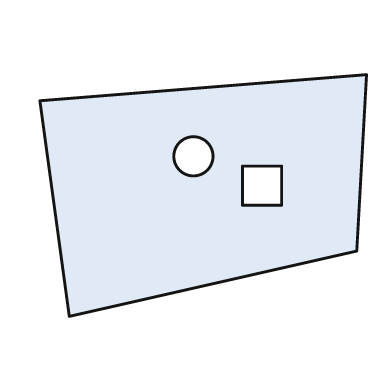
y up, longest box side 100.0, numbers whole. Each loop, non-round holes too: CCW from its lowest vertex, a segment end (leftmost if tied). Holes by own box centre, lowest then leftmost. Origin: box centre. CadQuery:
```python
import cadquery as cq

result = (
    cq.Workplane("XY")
    .moveTo(-41.0, -37.0)
    .lineTo(47.0, -17.0)
    .lineTo(50.0, 37.0)
    .lineTo(-50.0, 29.0)
    .close()
    .moveTo(12.0, -3.0)
    .lineTo(24.0, -3.0)
    .lineTo(24.0, 9.0)
    .lineTo(12.0, 9.0)
    .close()
    .moveTo(-3.0, 12.0)
    .circle(6.0)
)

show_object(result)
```